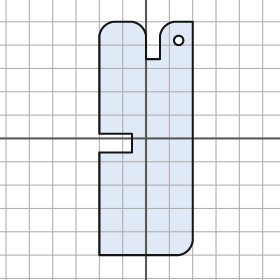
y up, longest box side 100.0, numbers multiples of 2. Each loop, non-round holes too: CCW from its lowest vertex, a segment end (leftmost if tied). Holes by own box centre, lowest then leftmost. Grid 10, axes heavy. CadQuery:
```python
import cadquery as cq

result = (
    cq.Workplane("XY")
    .moveTo(-20.0, -50.0)
    .lineTo(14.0, -50.0)
    .threePointArc((18.0, -48.0), (20.0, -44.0))
    .lineTo(20.0, 50.0)
    .lineTo(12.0, 50.0)
    .threePointArc((8.0, 48.0), (6.0, 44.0))
    .lineTo(6.0, 34.0)
    .lineTo(0.0, 34.0)
    .lineTo(0.0, 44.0)
    .threePointArc((-2.0, 48.0), (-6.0, 50.0))
    .lineTo(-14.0, 50.0)
    .threePointArc((-18.0, 48.0), (-20.0, 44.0))
    .lineTo(-20.0, 2.0)
    .lineTo(-6.0, 2.0)
    .lineTo(-6.0, -6.0)
    .lineTo(-20.0, -6.0)
    .close()
    .moveTo(14.0, 42.0)
    .circle(2.0)
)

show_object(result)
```